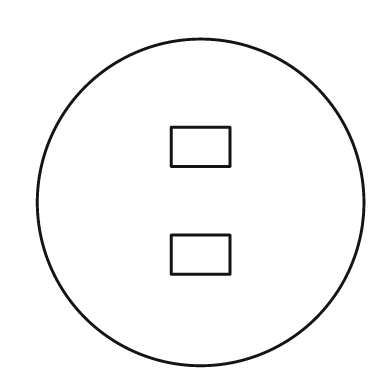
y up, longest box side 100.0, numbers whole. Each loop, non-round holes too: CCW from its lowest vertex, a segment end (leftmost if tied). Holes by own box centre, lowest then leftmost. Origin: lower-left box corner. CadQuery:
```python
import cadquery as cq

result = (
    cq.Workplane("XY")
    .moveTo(50.0, 50.0)
    .circle(50.0)
    .moveTo(41.0, 28.0)
    .lineTo(59.0, 28.0)
    .lineTo(59.0, 40.0)
    .lineTo(41.0, 40.0)
    .close()
    .moveTo(41.0, 61.0)
    .lineTo(59.0, 61.0)
    .lineTo(59.0, 73.0)
    .lineTo(41.0, 73.0)
    .close()
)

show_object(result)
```